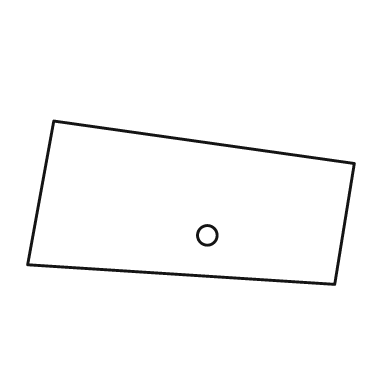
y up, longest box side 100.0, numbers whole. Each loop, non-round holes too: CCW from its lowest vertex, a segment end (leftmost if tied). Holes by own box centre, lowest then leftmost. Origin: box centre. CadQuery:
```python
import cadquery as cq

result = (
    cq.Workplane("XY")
    .moveTo(44.0, -25.0)
    .lineTo(50.0, 12.0)
    .lineTo(-42.0, 25.0)
    .lineTo(-50.0, -19.0)
    .close()
    .moveTo(5.0, -10.0)
    .circle(3.0)
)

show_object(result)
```